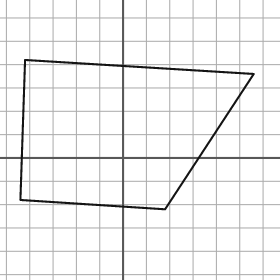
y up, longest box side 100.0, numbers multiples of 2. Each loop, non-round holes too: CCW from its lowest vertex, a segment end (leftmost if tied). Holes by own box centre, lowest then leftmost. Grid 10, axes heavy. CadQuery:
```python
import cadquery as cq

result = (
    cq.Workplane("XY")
    .moveTo(18.0, -22.0)
    .lineTo(56.0, 36.0)
    .lineTo(-42.0, 42.0)
    .lineTo(-44.0, -18.0)
    .close()
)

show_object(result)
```